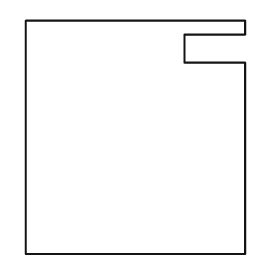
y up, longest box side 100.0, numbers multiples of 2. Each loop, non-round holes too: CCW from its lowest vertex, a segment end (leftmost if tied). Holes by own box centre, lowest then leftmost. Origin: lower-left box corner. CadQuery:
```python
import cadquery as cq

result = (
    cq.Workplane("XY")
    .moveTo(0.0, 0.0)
    .lineTo(94.0, 0.0)
    .lineTo(94.0, 82.0)
    .lineTo(68.0, 82.0)
    .lineTo(68.0, 94.0)
    .lineTo(94.0, 94.0)
    .lineTo(94.0, 100.0)
    .lineTo(0.0, 100.0)
    .close()
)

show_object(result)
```